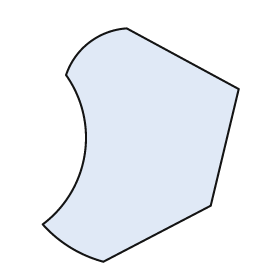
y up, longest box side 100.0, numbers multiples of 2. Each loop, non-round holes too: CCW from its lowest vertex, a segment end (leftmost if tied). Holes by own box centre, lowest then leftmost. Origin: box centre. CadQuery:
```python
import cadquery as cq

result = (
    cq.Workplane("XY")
    .moveTo(-16.0, -50.0)
    .lineTo(30.0, -26.0)
    .lineTo(42.0, 24.0)
    .lineTo(-6.0, 50.0)
    .threePointArc((-22.0, 44.0), (-32.0, 30.0))
    .threePointArc((-24.0, -4.0), (-42.0, -34.0))
    .threePointArc((-30.0, -44.0), (-16.0, -50.0))
    .close()
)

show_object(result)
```